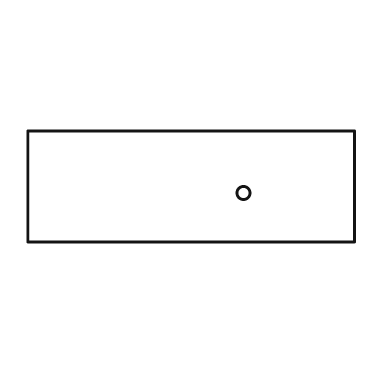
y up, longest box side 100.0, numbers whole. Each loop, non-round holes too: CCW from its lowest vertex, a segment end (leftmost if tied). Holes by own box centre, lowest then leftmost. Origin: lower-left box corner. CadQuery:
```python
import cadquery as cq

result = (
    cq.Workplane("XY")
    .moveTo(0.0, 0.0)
    .lineTo(100.0, 0.0)
    .lineTo(100.0, 34.0)
    .lineTo(0.0, 34.0)
    .close()
    .moveTo(66.0, 15.0)
    .circle(2.0)
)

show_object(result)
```